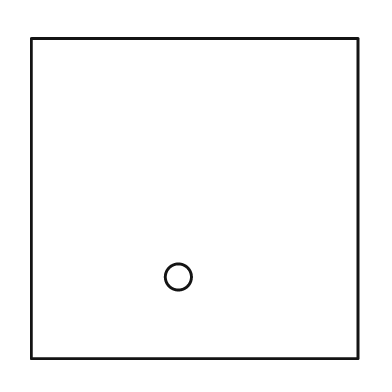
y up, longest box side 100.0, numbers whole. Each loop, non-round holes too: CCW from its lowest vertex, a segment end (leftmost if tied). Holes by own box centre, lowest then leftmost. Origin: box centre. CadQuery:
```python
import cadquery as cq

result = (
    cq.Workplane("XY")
    .moveTo(-50.0, -49.0)
    .lineTo(50.0, -49.0)
    .lineTo(50.0, 49.0)
    .lineTo(-50.0, 49.0)
    .close()
    .moveTo(-5.0, -24.0)
    .circle(4.0)
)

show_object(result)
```